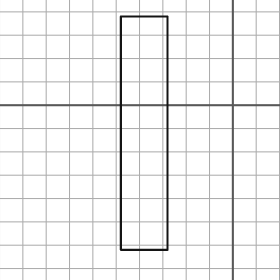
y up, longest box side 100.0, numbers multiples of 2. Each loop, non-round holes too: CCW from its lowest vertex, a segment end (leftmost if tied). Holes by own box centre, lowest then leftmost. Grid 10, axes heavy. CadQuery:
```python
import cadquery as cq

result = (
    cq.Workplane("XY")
    .moveTo(-48.0, -62.0)
    .lineTo(-28.0, -62.0)
    .lineTo(-28.0, 38.0)
    .lineTo(-48.0, 38.0)
    .close()
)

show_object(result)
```